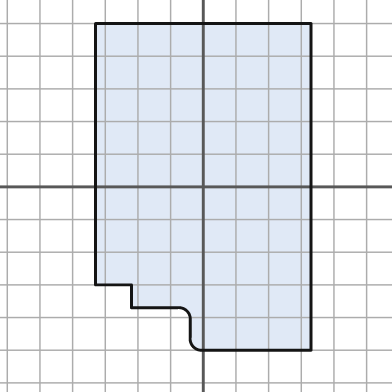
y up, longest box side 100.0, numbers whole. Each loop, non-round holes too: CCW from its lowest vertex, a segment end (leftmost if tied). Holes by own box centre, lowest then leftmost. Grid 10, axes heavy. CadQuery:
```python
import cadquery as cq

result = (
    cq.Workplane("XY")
    .moveTo(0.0, -50.0)
    .lineTo(33.0, -50.0)
    .lineTo(33.0, 50.0)
    .lineTo(-33.0, 50.0)
    .lineTo(-33.0, -30.0)
    .lineTo(-22.0, -30.0)
    .lineTo(-22.0, -37.0)
    .lineTo(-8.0, -37.0)
    .threePointArc((-5.0, -38.0), (-4.0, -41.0))
    .lineTo(-4.0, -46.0)
    .threePointArc((-3.0, -49.0), (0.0, -50.0))
    .close()
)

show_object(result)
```